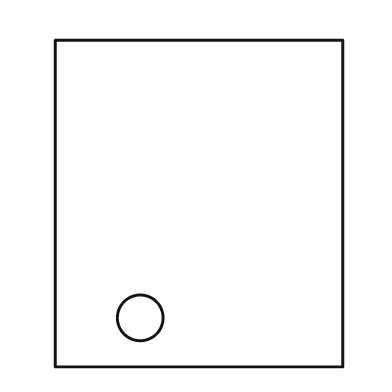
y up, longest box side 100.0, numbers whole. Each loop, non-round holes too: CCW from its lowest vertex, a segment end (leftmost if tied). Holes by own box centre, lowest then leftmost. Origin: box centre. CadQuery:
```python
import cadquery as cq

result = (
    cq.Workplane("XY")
    .moveTo(-44.0, -50.0)
    .lineTo(44.0, -50.0)
    .lineTo(44.0, 50.0)
    .lineTo(-44.0, 50.0)
    .close()
    .moveTo(-18.0, -35.0)
    .circle(7.0)
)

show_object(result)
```